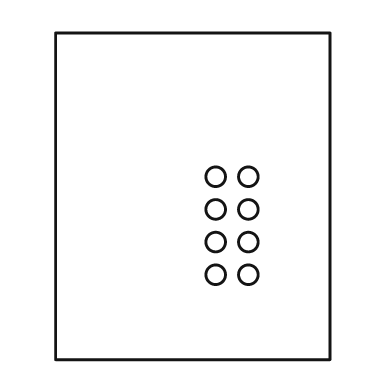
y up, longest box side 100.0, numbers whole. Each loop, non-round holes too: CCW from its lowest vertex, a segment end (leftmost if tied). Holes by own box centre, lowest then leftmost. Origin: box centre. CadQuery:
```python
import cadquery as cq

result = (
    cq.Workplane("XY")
    .moveTo(-42.0, -50.0)
    .lineTo(42.0, -50.0)
    .lineTo(42.0, 50.0)
    .lineTo(-42.0, 50.0)
    .close()
    .moveTo(7.0, -24.0)
    .circle(3.0)
    .moveTo(17.0, -24.0)
    .circle(3.0)
    .moveTo(7.0, -14.0)
    .circle(3.0)
    .moveTo(17.0, -14.0)
    .circle(3.0)
    .moveTo(7.0, -4.0)
    .circle(3.0)
    .moveTo(17.0, -4.0)
    .circle(3.0)
    .moveTo(7.0, 6.0)
    .circle(3.0)
    .moveTo(17.0, 6.0)
    .circle(3.0)
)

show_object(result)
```